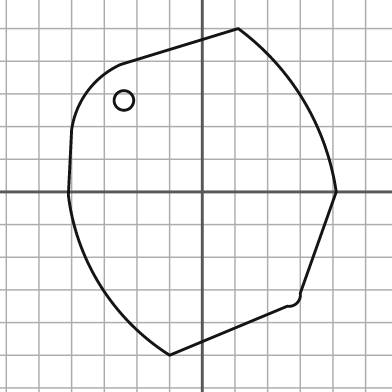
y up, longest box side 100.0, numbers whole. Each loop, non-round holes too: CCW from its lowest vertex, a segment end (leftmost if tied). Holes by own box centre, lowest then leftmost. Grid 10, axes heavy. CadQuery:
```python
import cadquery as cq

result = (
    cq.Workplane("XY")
    .moveTo(-10.0, -50.0)
    .lineTo(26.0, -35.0)
    .threePointArc((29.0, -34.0), (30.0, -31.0))
    .lineTo(41.0, 0.0)
    .threePointArc((31.0, 28.0), (11.0, 50.0))
    .lineTo(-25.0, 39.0)
    .threePointArc((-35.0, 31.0), (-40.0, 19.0))
    .lineTo(-41.0, -1.0)
    .threePointArc((-31.0, -29.0), (-10.0, -50.0))
    .close()
    .moveTo(-24.0, 28.0)
    .circle(3.0)
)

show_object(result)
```